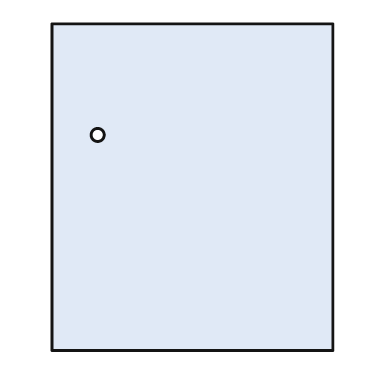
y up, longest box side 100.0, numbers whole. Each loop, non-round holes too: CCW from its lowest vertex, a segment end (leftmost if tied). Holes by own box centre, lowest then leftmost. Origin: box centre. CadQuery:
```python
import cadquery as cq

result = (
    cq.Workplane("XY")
    .moveTo(-43.0, -50.0)
    .lineTo(43.0, -50.0)
    .lineTo(43.0, 50.0)
    .lineTo(-43.0, 50.0)
    .close()
    .moveTo(-29.0, 16.0)
    .circle(2.0)
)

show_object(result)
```